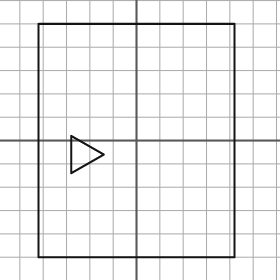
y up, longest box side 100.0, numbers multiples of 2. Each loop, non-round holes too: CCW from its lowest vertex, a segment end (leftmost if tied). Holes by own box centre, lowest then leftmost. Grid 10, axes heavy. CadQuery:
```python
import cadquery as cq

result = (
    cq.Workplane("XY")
    .moveTo(-42.0, -50.0)
    .lineTo(42.0, -50.0)
    .lineTo(42.0, 50.0)
    .lineTo(-42.0, 50.0)
    .close()
    .moveTo(-28.0, -14.0)
    .lineTo(-14.0, -6.0)
    .lineTo(-28.0, 2.0)
    .close()
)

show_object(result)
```